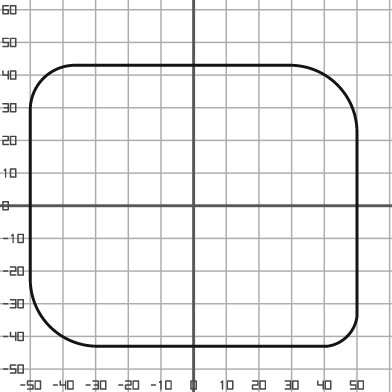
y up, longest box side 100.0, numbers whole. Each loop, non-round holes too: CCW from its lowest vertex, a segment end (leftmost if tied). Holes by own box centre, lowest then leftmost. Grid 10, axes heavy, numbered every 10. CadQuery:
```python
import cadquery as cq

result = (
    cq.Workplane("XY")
    .moveTo(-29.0, -43.0)
    .lineTo(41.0, -43.0)
    .threePointArc((47.0, -40.0), (50.0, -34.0))
    .lineTo(50.0, 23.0)
    .threePointArc((44.0, 37.0), (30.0, 43.0))
    .lineTo(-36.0, 43.0)
    .threePointArc((-46.0, 39.0), (-50.0, 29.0))
    .lineTo(-50.0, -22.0)
    .threePointArc((-44.0, -37.0), (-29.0, -43.0))
    .close()
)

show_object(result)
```